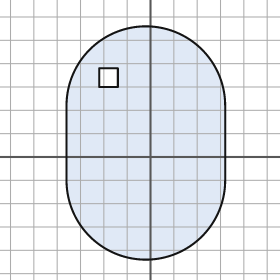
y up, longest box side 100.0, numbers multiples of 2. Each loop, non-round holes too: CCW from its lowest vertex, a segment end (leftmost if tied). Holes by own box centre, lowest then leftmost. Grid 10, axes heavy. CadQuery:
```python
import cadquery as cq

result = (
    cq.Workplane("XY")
    .moveTo(-36.0, -10.0)
    .threePointArc((-2.0, -44.0), (32.0, -10.0))
    .lineTo(32.0, 22.0)
    .threePointArc((-2.0, 56.0), (-36.0, 22.0))
    .close()
    .moveTo(-22.0, 30.0)
    .lineTo(-14.0, 30.0)
    .lineTo(-14.0, 38.0)
    .lineTo(-22.0, 38.0)
    .close()
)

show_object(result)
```